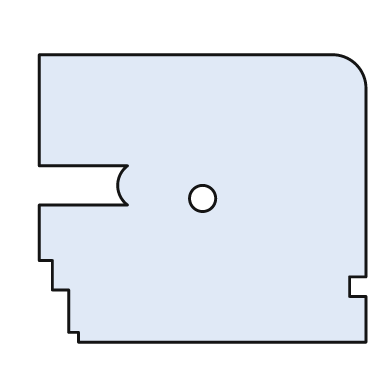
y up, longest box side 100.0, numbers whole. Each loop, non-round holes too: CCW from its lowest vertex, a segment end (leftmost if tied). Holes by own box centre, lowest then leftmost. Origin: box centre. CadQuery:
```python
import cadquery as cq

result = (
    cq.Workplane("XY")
    .moveTo(-38.0, -44.0)
    .lineTo(50.0, -44.0)
    .lineTo(50.0, -30.0)
    .lineTo(45.0, -30.0)
    .lineTo(45.0, -24.0)
    .lineTo(50.0, -24.0)
    .lineTo(50.0, 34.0)
    .threePointArc((47.0, 41.0), (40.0, 44.0))
    .lineTo(-50.0, 44.0)
    .lineTo(-50.0, 10.0)
    .lineTo(-23.0, 10.0)
    .threePointArc((-26.0, 4.0), (-23.0, -2.0))
    .lineTo(-50.0, -2.0)
    .lineTo(-50.0, -19.0)
    .lineTo(-46.0, -19.0)
    .lineTo(-46.0, -28.0)
    .lineTo(-41.0, -28.0)
    .lineTo(-41.0, -41.0)
    .lineTo(-38.0, -41.0)
    .close()
    .moveTo(0.0, 0.0)
    .circle(4.0)
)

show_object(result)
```